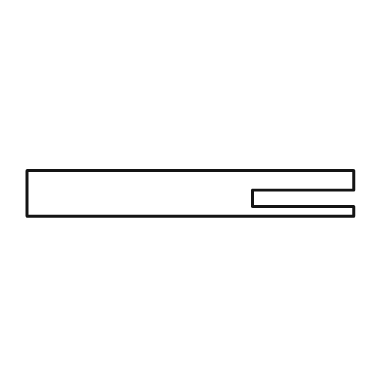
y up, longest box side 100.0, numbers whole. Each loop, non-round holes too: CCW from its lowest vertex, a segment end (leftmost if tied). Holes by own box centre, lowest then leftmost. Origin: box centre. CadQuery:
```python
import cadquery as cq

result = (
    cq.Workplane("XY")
    .moveTo(-50.0, -7.0)
    .lineTo(50.0, -7.0)
    .lineTo(50.0, -4.0)
    .lineTo(19.0, -4.0)
    .lineTo(19.0, 1.0)
    .lineTo(50.0, 1.0)
    .lineTo(50.0, 7.0)
    .lineTo(-50.0, 7.0)
    .close()
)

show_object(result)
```